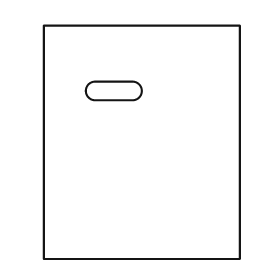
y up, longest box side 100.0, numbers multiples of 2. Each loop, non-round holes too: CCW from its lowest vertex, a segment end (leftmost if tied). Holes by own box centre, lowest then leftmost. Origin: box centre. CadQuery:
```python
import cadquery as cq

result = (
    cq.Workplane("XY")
    .moveTo(-42.0, -50.0)
    .lineTo(42.0, -50.0)
    .lineTo(42.0, 50.0)
    .lineTo(-42.0, 50.0)
    .close()
    .moveTo(-20.0, 18.0)
    .lineTo(-4.0, 18.0)
    .threePointArc((0.0, 22.0), (-4.0, 26.0))
    .lineTo(-20.0, 26.0)
    .threePointArc((-24.0, 22.0), (-20.0, 18.0))
    .close()
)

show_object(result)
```